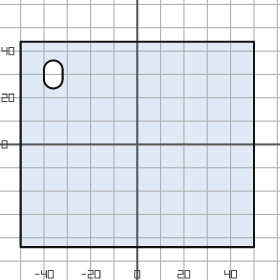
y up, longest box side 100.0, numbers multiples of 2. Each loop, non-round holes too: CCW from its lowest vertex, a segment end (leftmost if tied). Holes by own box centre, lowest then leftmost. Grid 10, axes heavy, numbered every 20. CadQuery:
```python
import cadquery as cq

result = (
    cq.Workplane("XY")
    .moveTo(-50.0, -44.0)
    .lineTo(50.0, -44.0)
    .lineTo(50.0, 44.0)
    .lineTo(-50.0, 44.0)
    .close()
    .moveTo(-40.0, 28.0)
    .threePointArc((-36.0, 24.0), (-32.0, 28.0))
    .lineTo(-32.0, 32.0)
    .threePointArc((-36.0, 36.0), (-40.0, 32.0))
    .close()
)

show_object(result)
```